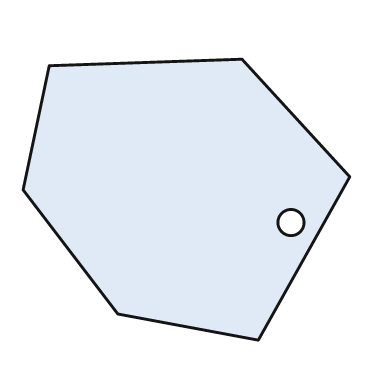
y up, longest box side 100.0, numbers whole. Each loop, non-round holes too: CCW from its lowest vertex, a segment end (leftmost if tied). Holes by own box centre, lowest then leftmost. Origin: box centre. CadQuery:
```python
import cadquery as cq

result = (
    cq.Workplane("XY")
    .moveTo(22.0, -43.0)
    .lineTo(50.0, 7.0)
    .lineTo(17.0, 43.0)
    .lineTo(-42.0, 41.0)
    .lineTo(-50.0, 3.0)
    .lineTo(-21.0, -35.0)
    .close()
    .moveTo(32.0, -7.0)
    .circle(4.0)
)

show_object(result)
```